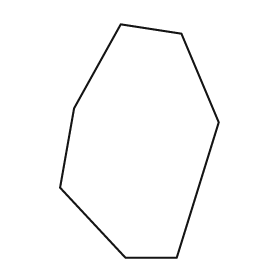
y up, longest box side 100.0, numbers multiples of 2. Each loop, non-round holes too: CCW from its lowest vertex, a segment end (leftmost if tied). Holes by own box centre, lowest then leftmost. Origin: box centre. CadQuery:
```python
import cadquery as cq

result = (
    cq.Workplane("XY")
    .moveTo(-6.0, -50.0)
    .lineTo(16.0, -50.0)
    .lineTo(34.0, 8.0)
    .lineTo(18.0, 46.0)
    .lineTo(-8.0, 50.0)
    .lineTo(-28.0, 14.0)
    .lineTo(-34.0, -20.0)
    .close()
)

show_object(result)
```